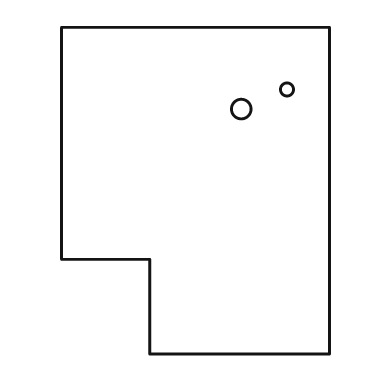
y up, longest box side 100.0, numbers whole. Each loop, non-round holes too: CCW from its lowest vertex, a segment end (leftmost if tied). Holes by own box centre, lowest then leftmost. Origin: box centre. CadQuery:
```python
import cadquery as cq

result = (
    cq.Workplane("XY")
    .moveTo(-14.0, -50.0)
    .lineTo(41.0, -50.0)
    .lineTo(41.0, 50.0)
    .lineTo(-41.0, 50.0)
    .lineTo(-41.0, -21.0)
    .lineTo(-14.0, -21.0)
    .close()
    .moveTo(14.0, 25.0)
    .circle(3.0)
    .moveTo(28.0, 31.0)
    .circle(2.0)
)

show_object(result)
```